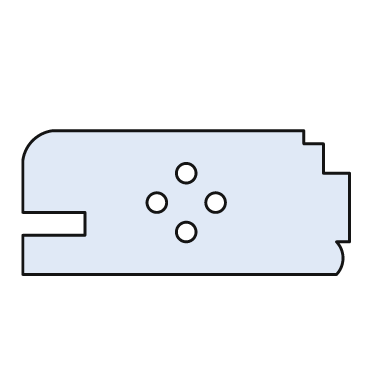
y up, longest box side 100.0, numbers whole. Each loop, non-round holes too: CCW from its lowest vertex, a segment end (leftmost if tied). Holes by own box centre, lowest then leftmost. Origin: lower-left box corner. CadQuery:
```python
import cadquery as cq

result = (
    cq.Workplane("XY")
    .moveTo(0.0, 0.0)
    .lineTo(96.0, 0.0)
    .threePointArc((98.0, 5.0), (96.0, 10.0))
    .lineTo(100.0, 10.0)
    .lineTo(100.0, 31.0)
    .lineTo(92.0, 31.0)
    .lineTo(92.0, 40.0)
    .lineTo(86.0, 40.0)
    .lineTo(86.0, 44.0)
    .lineTo(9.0, 44.0)
    .threePointArc((3.0, 41.0), (0.0, 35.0))
    .lineTo(0.0, 19.0)
    .lineTo(19.0, 19.0)
    .lineTo(19.0, 12.0)
    .lineTo(0.0, 12.0)
    .close()
    .moveTo(50.0, 13.0)
    .circle(3.0)
    .moveTo(41.0, 22.0)
    .circle(3.0)
    .moveTo(59.0, 22.0)
    .circle(3.0)
    .moveTo(50.0, 31.0)
    .circle(3.0)
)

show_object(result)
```